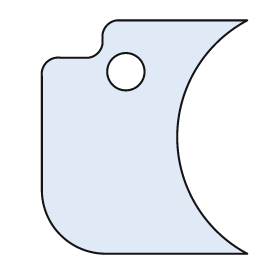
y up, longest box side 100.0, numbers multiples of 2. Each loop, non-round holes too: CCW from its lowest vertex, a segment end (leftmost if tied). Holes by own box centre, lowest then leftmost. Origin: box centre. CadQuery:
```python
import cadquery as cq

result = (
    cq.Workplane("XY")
    .moveTo(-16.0, -50.0)
    .lineTo(44.0, -50.0)
    .threePointArc((14.0, 0.0), (44.0, 50.0))
    .lineTo(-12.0, 50.0)
    .threePointArc((-16.0, 48.0), (-18.0, 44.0))
    .lineTo(-18.0, 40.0)
    .threePointArc((-20.0, 36.0), (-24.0, 34.0))
    .lineTo(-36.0, 34.0)
    .threePointArc((-42.0, 32.0), (-44.0, 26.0))
    .lineTo(-44.0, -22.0)
    .threePointArc((-36.0, -42.0), (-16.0, -50.0))
    .close()
    .moveTo(-8.0, 28.0)
    .circle(8.0)
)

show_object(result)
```